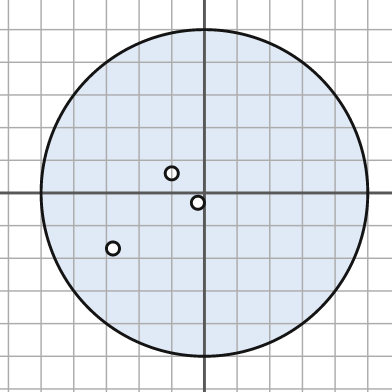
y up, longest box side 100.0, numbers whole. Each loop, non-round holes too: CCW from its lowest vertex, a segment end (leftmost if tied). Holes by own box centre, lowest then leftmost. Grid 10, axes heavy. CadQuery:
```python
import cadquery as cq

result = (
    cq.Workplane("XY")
    .moveTo(0.0, 0.0)
    .circle(50.0)
    .moveTo(-28.0, -17.0)
    .circle(2.0)
    .moveTo(-2.0, -3.0)
    .circle(2.0)
    .moveTo(-10.0, 6.0)
    .circle(2.0)
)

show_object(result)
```